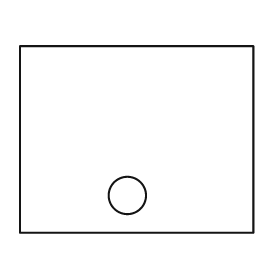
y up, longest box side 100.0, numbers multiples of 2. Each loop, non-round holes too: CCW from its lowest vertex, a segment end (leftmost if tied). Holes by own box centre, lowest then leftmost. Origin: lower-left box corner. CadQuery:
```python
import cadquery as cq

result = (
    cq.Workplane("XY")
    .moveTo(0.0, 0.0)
    .lineTo(100.0, 0.0)
    .lineTo(100.0, 80.0)
    .lineTo(0.0, 80.0)
    .close()
    .moveTo(46.0, 16.0)
    .circle(8.0)
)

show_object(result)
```